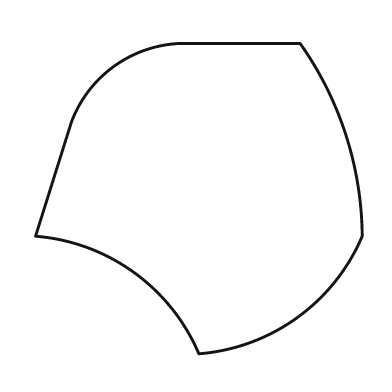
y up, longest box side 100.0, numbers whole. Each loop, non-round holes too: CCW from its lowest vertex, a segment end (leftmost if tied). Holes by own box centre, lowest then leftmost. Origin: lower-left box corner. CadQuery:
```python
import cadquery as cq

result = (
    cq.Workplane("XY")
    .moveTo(50.0, 0.0)
    .threePointArc((80.0, 11.0), (100.0, 36.0))
    .threePointArc((95.0, 67.0), (81.0, 95.0))
    .lineTo(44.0, 95.0)
    .threePointArc((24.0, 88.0), (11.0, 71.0))
    .lineTo(0.0, 36.0)
    .threePointArc((30.0, 25.0), (50.0, 0.0))
    .close()
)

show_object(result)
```